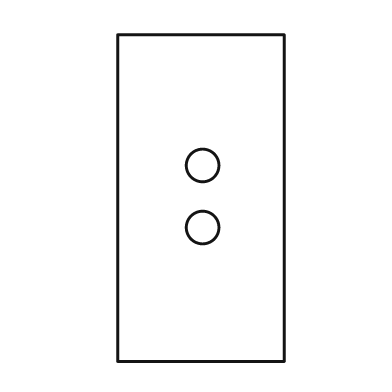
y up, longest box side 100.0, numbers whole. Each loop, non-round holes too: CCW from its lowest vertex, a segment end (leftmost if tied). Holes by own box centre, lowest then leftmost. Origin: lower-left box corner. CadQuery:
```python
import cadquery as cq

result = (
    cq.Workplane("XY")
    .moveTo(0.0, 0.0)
    .lineTo(51.0, 0.0)
    .lineTo(51.0, 100.0)
    .lineTo(0.0, 100.0)
    .close()
    .moveTo(26.0, 41.0)
    .circle(5.0)
    .moveTo(26.0, 60.0)
    .circle(5.0)
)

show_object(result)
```